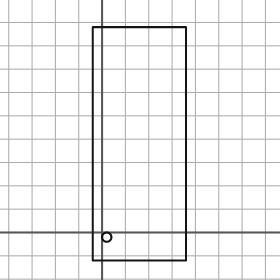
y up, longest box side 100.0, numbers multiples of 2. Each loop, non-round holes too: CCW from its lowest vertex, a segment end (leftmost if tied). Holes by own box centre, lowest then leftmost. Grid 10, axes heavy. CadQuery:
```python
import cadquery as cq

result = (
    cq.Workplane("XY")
    .moveTo(-4.0, -12.0)
    .lineTo(36.0, -12.0)
    .lineTo(36.0, 88.0)
    .lineTo(-4.0, 88.0)
    .close()
    .moveTo(2.0, -2.0)
    .circle(2.0)
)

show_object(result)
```